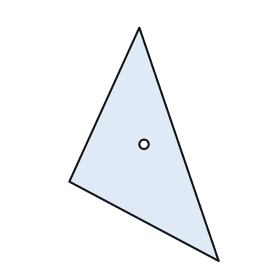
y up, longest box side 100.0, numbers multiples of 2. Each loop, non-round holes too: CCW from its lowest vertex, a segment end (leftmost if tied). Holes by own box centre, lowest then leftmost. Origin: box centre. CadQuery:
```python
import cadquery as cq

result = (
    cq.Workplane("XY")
    .moveTo(32.0, -50.0)
    .lineTo(-2.0, 50.0)
    .lineTo(-32.0, -16.0)
    .close()
    .moveTo(0.0, 0.0)
    .circle(2.0)
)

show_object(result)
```